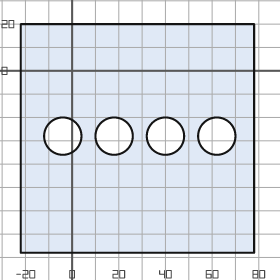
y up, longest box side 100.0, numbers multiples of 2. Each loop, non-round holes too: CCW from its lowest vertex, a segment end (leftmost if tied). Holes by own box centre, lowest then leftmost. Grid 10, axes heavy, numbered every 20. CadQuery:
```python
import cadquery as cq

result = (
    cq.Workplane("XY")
    .moveTo(-22.0, -78.0)
    .lineTo(78.0, -78.0)
    .lineTo(78.0, 20.0)
    .lineTo(-22.0, 20.0)
    .close()
    .moveTo(-4.0, -28.0)
    .circle(8.0)
    .moveTo(18.0, -28.0)
    .circle(8.0)
    .moveTo(40.0, -28.0)
    .circle(8.0)
    .moveTo(62.0, -28.0)
    .circle(8.0)
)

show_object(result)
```